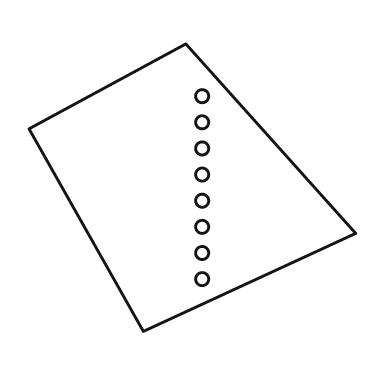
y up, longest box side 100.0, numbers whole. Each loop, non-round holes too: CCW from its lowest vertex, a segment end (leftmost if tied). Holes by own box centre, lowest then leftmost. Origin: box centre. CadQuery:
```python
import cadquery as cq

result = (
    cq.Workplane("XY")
    .moveTo(-15.0, -44.0)
    .lineTo(50.0, -14.0)
    .lineTo(-2.0, 44.0)
    .lineTo(-50.0, 18.0)
    .close()
    .moveTo(3.0, -28.0)
    .circle(2.0)
    .moveTo(3.0, -20.0)
    .circle(2.0)
    .moveTo(3.0, -12.0)
    .circle(2.0)
    .moveTo(3.0, -4.0)
    .circle(2.0)
    .moveTo(3.0, 4.0)
    .circle(2.0)
    .moveTo(3.0, 12.0)
    .circle(2.0)
    .moveTo(3.0, 20.0)
    .circle(2.0)
    .moveTo(3.0, 28.0)
    .circle(2.0)
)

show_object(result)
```